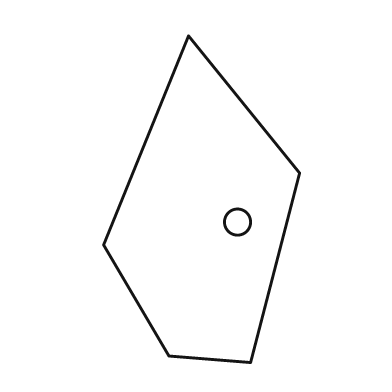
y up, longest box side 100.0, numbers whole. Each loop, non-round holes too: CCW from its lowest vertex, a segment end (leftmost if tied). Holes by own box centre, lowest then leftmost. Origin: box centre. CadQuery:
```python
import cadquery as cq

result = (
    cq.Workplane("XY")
    .moveTo(15.0, -50.0)
    .lineTo(30.0, 8.0)
    .lineTo(-4.0, 50.0)
    .lineTo(-30.0, -14.0)
    .lineTo(-10.0, -48.0)
    .close()
    .moveTo(11.0, -7.0)
    .circle(4.0)
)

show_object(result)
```